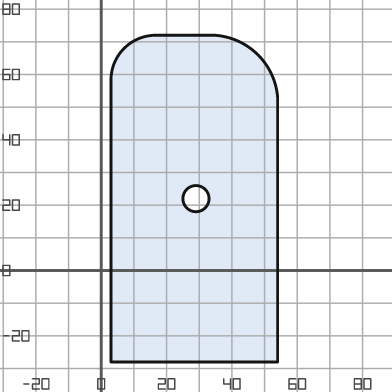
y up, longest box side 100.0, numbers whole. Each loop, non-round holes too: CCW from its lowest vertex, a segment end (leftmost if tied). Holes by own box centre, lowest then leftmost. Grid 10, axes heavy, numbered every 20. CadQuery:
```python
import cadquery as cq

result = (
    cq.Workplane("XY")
    .moveTo(3.0, -28.0)
    .lineTo(54.0, -28.0)
    .lineTo(54.0, 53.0)
    .threePointArc((48.0, 66.0), (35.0, 72.0))
    .lineTo(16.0, 72.0)
    .threePointArc((7.0, 68.0), (3.0, 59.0))
    .close()
    .moveTo(29.0, 22.0)
    .circle(4.0)
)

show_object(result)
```